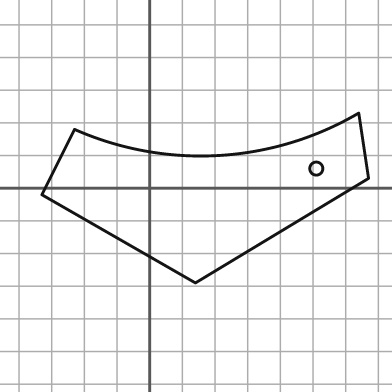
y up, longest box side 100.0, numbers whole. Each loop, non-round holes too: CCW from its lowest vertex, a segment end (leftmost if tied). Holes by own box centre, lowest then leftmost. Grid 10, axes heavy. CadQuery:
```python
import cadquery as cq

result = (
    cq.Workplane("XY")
    .moveTo(14.0, -29.0)
    .lineTo(67.0, 3.0)
    .lineTo(64.0, 23.0)
    .threePointArc((21.0, 10.0), (-23.0, 18.0))
    .lineTo(-33.0, -2.0)
    .close()
    .moveTo(51.0, 6.0)
    .circle(2.0)
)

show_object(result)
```